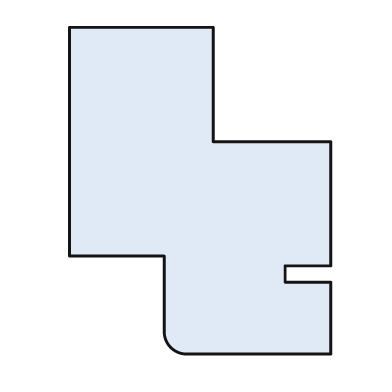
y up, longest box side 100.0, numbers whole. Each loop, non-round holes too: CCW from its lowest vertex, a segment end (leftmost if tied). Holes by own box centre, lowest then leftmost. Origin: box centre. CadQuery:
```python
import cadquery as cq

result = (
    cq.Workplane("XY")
    .moveTo(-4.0, -50.0)
    .lineTo(40.0, -50.0)
    .lineTo(40.0, -28.0)
    .lineTo(26.0, -28.0)
    .lineTo(26.0, -23.0)
    .lineTo(40.0, -23.0)
    .lineTo(40.0, 15.0)
    .lineTo(4.0, 15.0)
    .lineTo(4.0, 50.0)
    .lineTo(-40.0, 50.0)
    .lineTo(-40.0, -20.0)
    .lineTo(-11.0, -20.0)
    .lineTo(-11.0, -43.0)
    .threePointArc((-9.0, -48.0), (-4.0, -50.0))
    .close()
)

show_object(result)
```